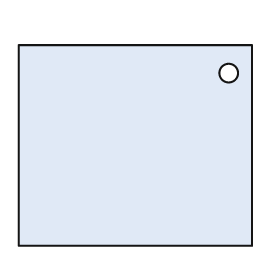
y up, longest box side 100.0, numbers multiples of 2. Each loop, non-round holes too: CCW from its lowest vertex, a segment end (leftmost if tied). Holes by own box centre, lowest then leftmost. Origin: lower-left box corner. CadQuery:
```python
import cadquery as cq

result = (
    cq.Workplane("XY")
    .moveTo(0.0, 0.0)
    .lineTo(100.0, 0.0)
    .lineTo(100.0, 86.0)
    .lineTo(0.0, 86.0)
    .close()
    .moveTo(90.0, 74.0)
    .circle(4.0)
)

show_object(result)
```